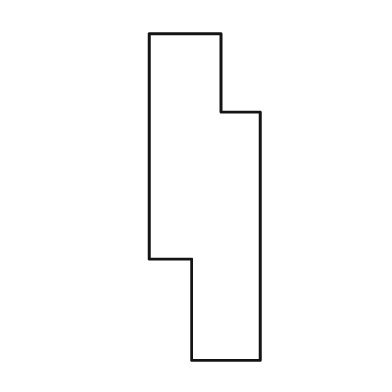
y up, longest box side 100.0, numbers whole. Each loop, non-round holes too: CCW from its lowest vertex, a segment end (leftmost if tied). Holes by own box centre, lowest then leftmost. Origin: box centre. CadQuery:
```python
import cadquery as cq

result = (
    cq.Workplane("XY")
    .moveTo(-4.0, -50.0)
    .lineTo(17.0, -50.0)
    .lineTo(17.0, 26.0)
    .lineTo(5.0, 26.0)
    .lineTo(5.0, 50.0)
    .lineTo(-17.0, 50.0)
    .lineTo(-17.0, -19.0)
    .lineTo(-4.0, -19.0)
    .close()
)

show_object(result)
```